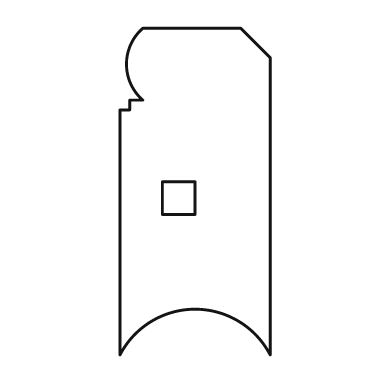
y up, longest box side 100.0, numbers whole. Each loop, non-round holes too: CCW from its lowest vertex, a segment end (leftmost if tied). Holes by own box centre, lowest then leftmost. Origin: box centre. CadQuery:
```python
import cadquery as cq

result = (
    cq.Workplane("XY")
    .moveTo(-23.0, -50.0)
    .threePointArc((0.0, -36.0), (23.0, -50.0))
    .lineTo(23.0, 41.0)
    .lineTo(14.0, 50.0)
    .lineTo(-16.0, 50.0)
    .threePointArc((-21.0, 39.0), (-16.0, 28.0))
    .lineTo(-20.0, 28.0)
    .lineTo(-20.0, 25.0)
    .lineTo(-23.0, 25.0)
    .close()
    .moveTo(-10.0, -7.0)
    .lineTo(0.0, -7.0)
    .lineTo(0.0, 3.0)
    .lineTo(-10.0, 3.0)
    .close()
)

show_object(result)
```